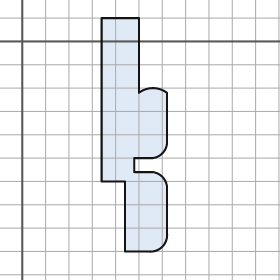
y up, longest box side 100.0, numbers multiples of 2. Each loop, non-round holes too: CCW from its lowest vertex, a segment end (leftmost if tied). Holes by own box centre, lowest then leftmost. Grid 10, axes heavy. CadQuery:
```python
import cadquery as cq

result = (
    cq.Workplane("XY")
    .moveTo(44.0, -90.0)
    .lineTo(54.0, -90.0)
    .threePointArc((60.0, -88.0), (62.0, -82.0))
    .lineTo(62.0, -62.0)
    .threePointArc((60.0, -58.0), (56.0, -56.0))
    .lineTo(48.0, -56.0)
    .lineTo(48.0, -50.0)
    .lineTo(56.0, -50.0)
    .threePointArc((60.0, -48.0), (62.0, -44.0))
    .lineTo(62.0, -22.0)
    .threePointArc((56.0, -20.0), (50.0, -22.0))
    .lineTo(50.0, 10.0)
    .lineTo(34.0, 10.0)
    .lineTo(34.0, -60.0)
    .lineTo(44.0, -60.0)
    .close()
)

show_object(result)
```